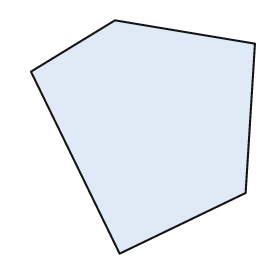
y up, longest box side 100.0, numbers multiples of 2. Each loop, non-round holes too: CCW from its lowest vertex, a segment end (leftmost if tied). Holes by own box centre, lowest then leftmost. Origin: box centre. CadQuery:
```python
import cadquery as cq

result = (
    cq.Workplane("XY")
    .moveTo(-10.0, -50.0)
    .lineTo(44.0, -24.0)
    .lineTo(48.0, 40.0)
    .lineTo(-12.0, 50.0)
    .lineTo(-48.0, 28.0)
    .close()
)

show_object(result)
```